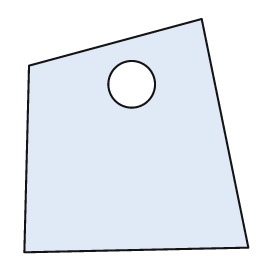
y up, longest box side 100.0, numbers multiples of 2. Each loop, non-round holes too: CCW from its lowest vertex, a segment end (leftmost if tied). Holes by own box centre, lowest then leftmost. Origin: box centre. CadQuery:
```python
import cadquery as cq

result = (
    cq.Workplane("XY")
    .moveTo(-48.0, -50.0)
    .lineTo(48.0, -48.0)
    .lineTo(28.0, 50.0)
    .lineTo(-46.0, 30.0)
    .close()
    .moveTo(-2.0, 22.0)
    .circle(10.0)
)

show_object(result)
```